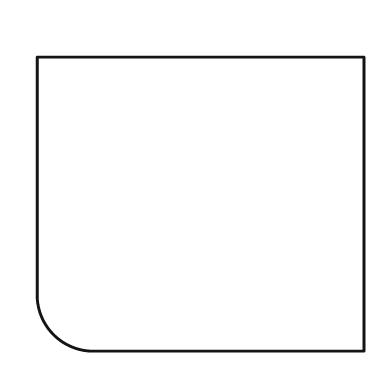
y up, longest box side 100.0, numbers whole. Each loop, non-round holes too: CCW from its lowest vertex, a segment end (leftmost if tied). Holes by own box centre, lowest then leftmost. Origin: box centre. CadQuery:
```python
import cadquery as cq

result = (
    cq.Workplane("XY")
    .moveTo(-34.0, -45.0)
    .lineTo(50.0, -45.0)
    .lineTo(50.0, 45.0)
    .lineTo(-50.0, 45.0)
    .lineTo(-50.0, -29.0)
    .threePointArc((-45.0, -40.0), (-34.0, -45.0))
    .close()
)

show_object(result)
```